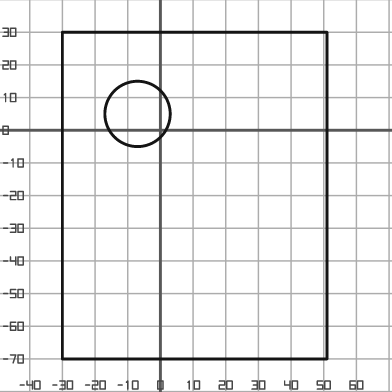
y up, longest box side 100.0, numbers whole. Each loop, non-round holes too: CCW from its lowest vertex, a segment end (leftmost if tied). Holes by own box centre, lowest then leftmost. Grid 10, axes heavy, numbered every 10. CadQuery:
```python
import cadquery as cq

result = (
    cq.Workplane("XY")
    .moveTo(-30.0, -70.0)
    .lineTo(51.0, -70.0)
    .lineTo(51.0, 30.0)
    .lineTo(-30.0, 30.0)
    .close()
    .moveTo(-7.0, 5.0)
    .circle(10.0)
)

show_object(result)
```